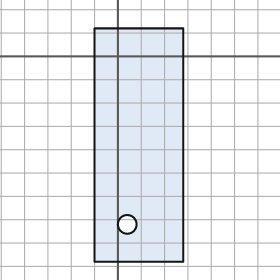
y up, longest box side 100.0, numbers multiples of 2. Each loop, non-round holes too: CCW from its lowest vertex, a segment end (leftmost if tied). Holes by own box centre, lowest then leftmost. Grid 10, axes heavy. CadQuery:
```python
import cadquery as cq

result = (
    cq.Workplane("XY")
    .moveTo(-10.0, -88.0)
    .lineTo(28.0, -88.0)
    .lineTo(28.0, 12.0)
    .lineTo(-10.0, 12.0)
    .close()
    .moveTo(4.0, -72.0)
    .circle(4.0)
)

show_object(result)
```